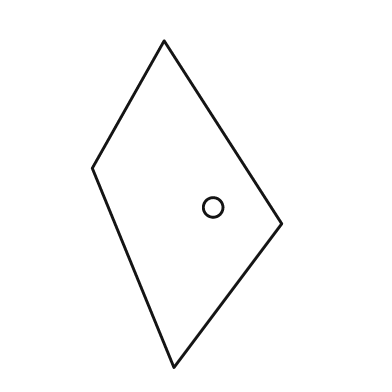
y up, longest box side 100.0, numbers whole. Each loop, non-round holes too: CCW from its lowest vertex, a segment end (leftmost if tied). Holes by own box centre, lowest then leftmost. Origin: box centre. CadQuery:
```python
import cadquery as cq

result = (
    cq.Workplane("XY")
    .moveTo(-4.0, -50.0)
    .lineTo(29.0, -6.0)
    .lineTo(-7.0, 50.0)
    .lineTo(-29.0, 11.0)
    .close()
    .moveTo(8.0, -1.0)
    .circle(3.0)
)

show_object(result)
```